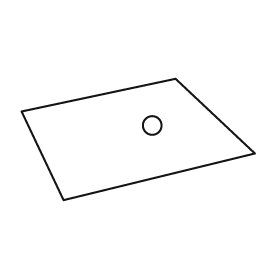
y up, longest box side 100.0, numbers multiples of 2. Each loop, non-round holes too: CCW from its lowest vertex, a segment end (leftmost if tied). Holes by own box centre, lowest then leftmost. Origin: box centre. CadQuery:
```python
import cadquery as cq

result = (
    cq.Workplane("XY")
    .moveTo(-32.0, -26.0)
    .lineTo(50.0, -6.0)
    .lineTo(16.0, 26.0)
    .lineTo(-50.0, 12.0)
    .close()
    .moveTo(6.0, 6.0)
    .circle(4.0)
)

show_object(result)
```